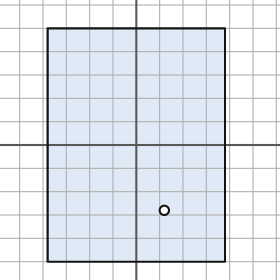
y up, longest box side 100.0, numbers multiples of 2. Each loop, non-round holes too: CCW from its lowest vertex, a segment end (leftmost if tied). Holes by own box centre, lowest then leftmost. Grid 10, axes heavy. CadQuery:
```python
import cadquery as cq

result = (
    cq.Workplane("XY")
    .moveTo(-38.0, -50.0)
    .lineTo(38.0, -50.0)
    .lineTo(38.0, 50.0)
    .lineTo(-38.0, 50.0)
    .close()
    .moveTo(12.0, -28.0)
    .circle(2.0)
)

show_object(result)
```